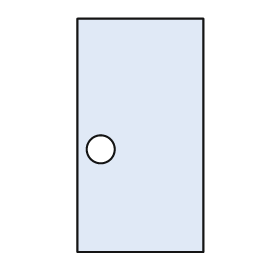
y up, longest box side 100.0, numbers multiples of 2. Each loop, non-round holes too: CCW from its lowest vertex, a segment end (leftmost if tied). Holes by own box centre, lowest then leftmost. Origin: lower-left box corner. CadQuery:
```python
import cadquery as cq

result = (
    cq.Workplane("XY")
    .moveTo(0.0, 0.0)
    .lineTo(54.0, 0.0)
    .lineTo(54.0, 100.0)
    .lineTo(0.0, 100.0)
    .close()
    .moveTo(10.0, 44.0)
    .circle(6.0)
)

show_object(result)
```